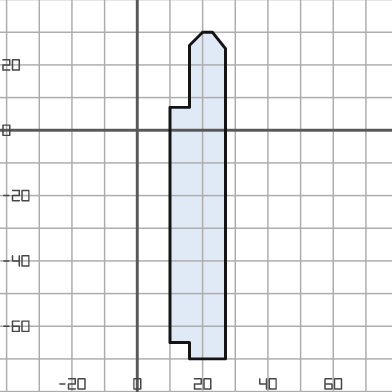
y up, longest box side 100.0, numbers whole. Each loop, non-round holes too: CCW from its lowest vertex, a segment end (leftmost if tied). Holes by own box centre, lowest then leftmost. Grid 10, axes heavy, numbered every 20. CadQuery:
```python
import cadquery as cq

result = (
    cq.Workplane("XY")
    .moveTo(16.0, -70.0)
    .lineTo(27.0, -70.0)
    .lineTo(27.0, 25.0)
    .lineTo(23.0, 30.0)
    .lineTo(20.0, 30.0)
    .lineTo(16.0, 26.0)
    .lineTo(16.0, 7.0)
    .lineTo(10.0, 7.0)
    .lineTo(10.0, -65.0)
    .lineTo(16.0, -65.0)
    .close()
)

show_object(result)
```